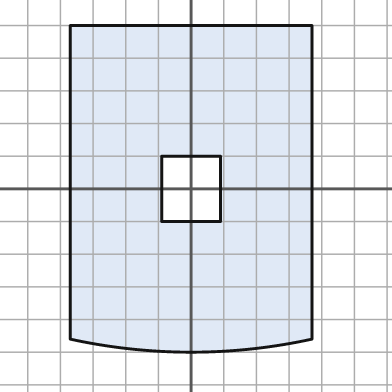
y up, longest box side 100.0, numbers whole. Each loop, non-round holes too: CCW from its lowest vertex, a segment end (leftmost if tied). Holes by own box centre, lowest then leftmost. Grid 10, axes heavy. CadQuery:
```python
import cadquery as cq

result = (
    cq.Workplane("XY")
    .moveTo(-37.0, -46.0)
    .threePointArc((0.0, -50.0), (37.0, -46.0))
    .lineTo(37.0, 50.0)
    .lineTo(-37.0, 50.0)
    .close()
    .moveTo(-9.0, -10.0)
    .lineTo(9.0, -10.0)
    .lineTo(9.0, 10.0)
    .lineTo(-9.0, 10.0)
    .close()
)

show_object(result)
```